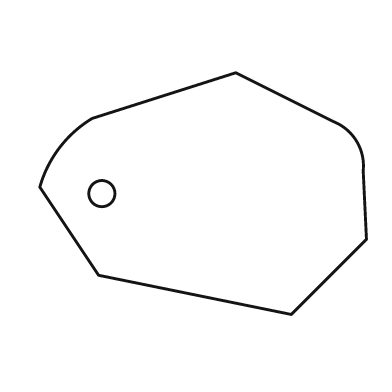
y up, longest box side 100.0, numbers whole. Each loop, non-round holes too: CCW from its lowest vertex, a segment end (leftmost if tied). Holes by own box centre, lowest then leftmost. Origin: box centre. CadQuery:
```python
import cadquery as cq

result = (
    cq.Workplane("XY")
    .moveTo(27.0, -37.0)
    .lineTo(50.0, -14.0)
    .lineTo(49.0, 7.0)
    .threePointArc((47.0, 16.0), (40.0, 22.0))
    .lineTo(10.0, 37.0)
    .lineTo(-34.0, 23.0)
    .threePointArc((-44.0, 14.0), (-50.0, 2.0))
    .lineTo(-32.0, -25.0)
    .close()
    .moveTo(-31.0, 0.0)
    .circle(4.0)
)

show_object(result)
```